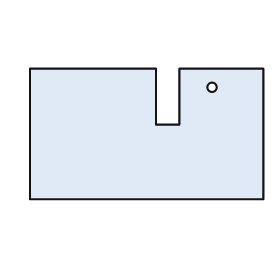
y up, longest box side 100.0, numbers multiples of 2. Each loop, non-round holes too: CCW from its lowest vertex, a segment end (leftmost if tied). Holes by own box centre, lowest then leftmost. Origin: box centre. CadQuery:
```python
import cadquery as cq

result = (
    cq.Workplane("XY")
    .moveTo(-50.0, -28.0)
    .lineTo(50.0, -28.0)
    .lineTo(50.0, 28.0)
    .lineTo(14.0, 28.0)
    .lineTo(14.0, 4.0)
    .lineTo(4.0, 4.0)
    .lineTo(4.0, 28.0)
    .lineTo(-50.0, 28.0)
    .close()
    .moveTo(28.0, 20.0)
    .circle(2.0)
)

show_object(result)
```